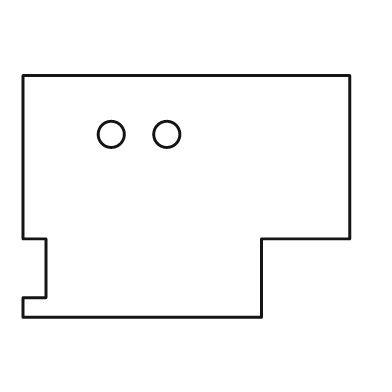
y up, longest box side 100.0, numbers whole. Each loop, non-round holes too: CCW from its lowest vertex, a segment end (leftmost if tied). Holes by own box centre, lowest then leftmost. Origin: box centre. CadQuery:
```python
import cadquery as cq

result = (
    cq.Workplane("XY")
    .moveTo(-50.0, -37.0)
    .lineTo(23.0, -37.0)
    .lineTo(23.0, -13.0)
    .lineTo(50.0, -13.0)
    .lineTo(50.0, 37.0)
    .lineTo(-50.0, 37.0)
    .lineTo(-50.0, -13.0)
    .lineTo(-43.0, -13.0)
    .lineTo(-43.0, -31.0)
    .lineTo(-50.0, -31.0)
    .close()
    .moveTo(-23.0, 19.0)
    .circle(4.0)
    .moveTo(-6.0, 19.0)
    .circle(4.0)
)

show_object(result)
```